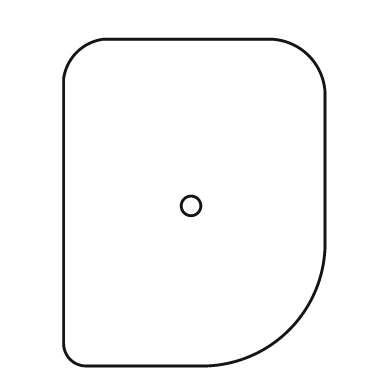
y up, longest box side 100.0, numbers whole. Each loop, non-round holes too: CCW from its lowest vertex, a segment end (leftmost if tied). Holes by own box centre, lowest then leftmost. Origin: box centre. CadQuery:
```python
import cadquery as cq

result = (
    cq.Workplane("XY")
    .moveTo(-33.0, -50.0)
    .lineTo(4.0, -50.0)
    .threePointArc((29.0, -39.0), (40.0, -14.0))
    .lineTo(40.0, 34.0)
    .threePointArc((35.0, 45.0), (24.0, 50.0))
    .lineTo(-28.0, 50.0)
    .threePointArc((-36.0, 46.0), (-40.0, 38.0))
    .lineTo(-40.0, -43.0)
    .threePointArc((-38.0, -48.0), (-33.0, -50.0))
    .close()
    .moveTo(-1.0, -1.0)
    .circle(3.0)
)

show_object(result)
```